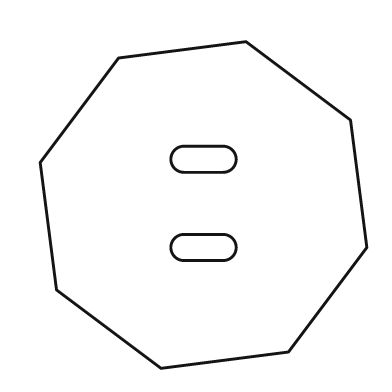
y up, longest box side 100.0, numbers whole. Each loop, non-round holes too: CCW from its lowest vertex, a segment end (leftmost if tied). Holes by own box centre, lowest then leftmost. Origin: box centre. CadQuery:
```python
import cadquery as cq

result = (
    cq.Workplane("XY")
    .moveTo(-13.0, -50.0)
    .lineTo(26.0, -45.0)
    .lineTo(50.0, -13.0)
    .lineTo(45.0, 26.0)
    .lineTo(13.0, 50.0)
    .lineTo(-26.0, 45.0)
    .lineTo(-50.0, 13.0)
    .lineTo(-45.0, -26.0)
    .close()
    .moveTo(-6.0, -17.0)
    .lineTo(6.0, -17.0)
    .threePointArc((10.0, -13.0), (6.0, -9.0))
    .lineTo(-6.0, -9.0)
    .threePointArc((-10.0, -13.0), (-6.0, -17.0))
    .close()
    .moveTo(-6.0, 10.0)
    .lineTo(6.0, 10.0)
    .threePointArc((10.0, 14.0), (6.0, 18.0))
    .lineTo(-6.0, 18.0)
    .threePointArc((-10.0, 14.0), (-6.0, 10.0))
    .close()
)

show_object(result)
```